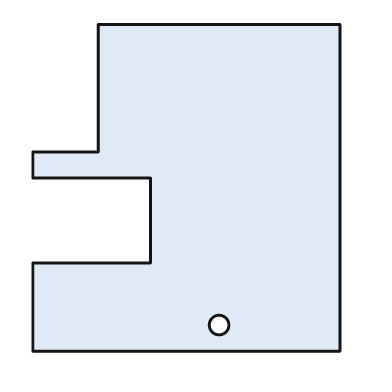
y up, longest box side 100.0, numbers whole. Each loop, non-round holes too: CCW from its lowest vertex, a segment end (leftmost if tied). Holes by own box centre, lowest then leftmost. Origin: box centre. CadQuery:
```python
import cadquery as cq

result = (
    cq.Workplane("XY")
    .moveTo(-47.0, -50.0)
    .lineTo(47.0, -50.0)
    .lineTo(47.0, 50.0)
    .lineTo(-27.0, 50.0)
    .lineTo(-27.0, 11.0)
    .lineTo(-47.0, 11.0)
    .lineTo(-47.0, 3.0)
    .lineTo(-11.0, 3.0)
    .lineTo(-11.0, -23.0)
    .lineTo(-47.0, -23.0)
    .close()
    .moveTo(10.0, -42.0)
    .circle(3.0)
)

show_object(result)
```